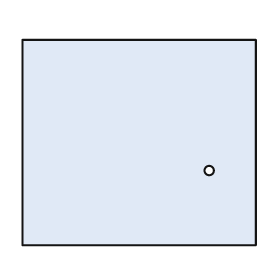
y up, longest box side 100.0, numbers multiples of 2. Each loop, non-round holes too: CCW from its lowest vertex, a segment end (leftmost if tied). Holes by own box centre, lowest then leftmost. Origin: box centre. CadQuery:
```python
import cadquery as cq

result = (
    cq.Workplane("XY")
    .moveTo(-50.0, -44.0)
    .lineTo(50.0, -44.0)
    .lineTo(50.0, 44.0)
    .lineTo(-50.0, 44.0)
    .close()
    .moveTo(30.0, -12.0)
    .circle(2.0)
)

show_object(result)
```